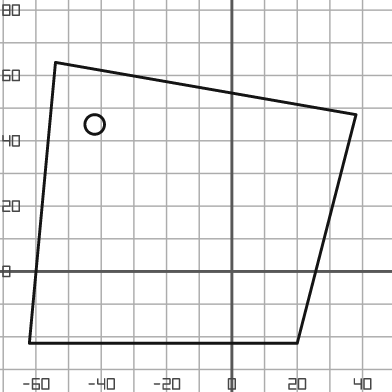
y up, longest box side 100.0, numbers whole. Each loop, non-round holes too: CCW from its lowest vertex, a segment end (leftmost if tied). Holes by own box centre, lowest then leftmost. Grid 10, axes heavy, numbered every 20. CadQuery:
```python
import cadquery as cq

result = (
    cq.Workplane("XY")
    .moveTo(-62.0, -22.0)
    .lineTo(20.0, -22.0)
    .lineTo(38.0, 48.0)
    .lineTo(-54.0, 64.0)
    .close()
    .moveTo(-42.0, 45.0)
    .circle(3.0)
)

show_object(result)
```